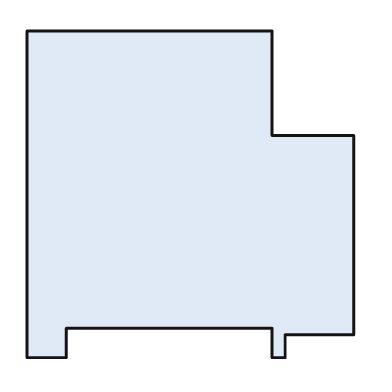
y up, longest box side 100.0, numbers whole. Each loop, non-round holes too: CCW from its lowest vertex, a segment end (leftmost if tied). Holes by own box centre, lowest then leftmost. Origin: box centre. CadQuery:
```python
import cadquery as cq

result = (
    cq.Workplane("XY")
    .moveTo(-50.0, -50.0)
    .lineTo(-38.0, -50.0)
    .lineTo(-38.0, -41.0)
    .lineTo(25.0, -41.0)
    .lineTo(25.0, -50.0)
    .lineTo(29.0, -50.0)
    .lineTo(29.0, -43.0)
    .lineTo(50.0, -43.0)
    .lineTo(50.0, 18.0)
    .lineTo(25.0, 18.0)
    .lineTo(25.0, 50.0)
    .lineTo(-50.0, 50.0)
    .close()
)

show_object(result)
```